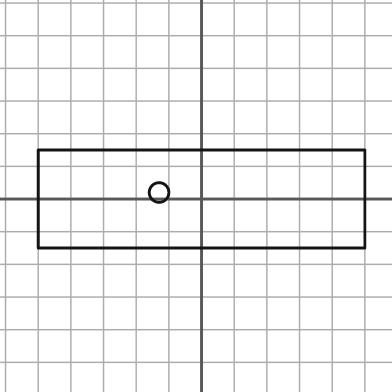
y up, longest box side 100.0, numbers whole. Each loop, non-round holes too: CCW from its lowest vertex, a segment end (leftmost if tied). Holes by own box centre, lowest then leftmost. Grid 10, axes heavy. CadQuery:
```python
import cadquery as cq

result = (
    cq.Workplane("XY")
    .moveTo(-50.0, -15.0)
    .lineTo(50.0, -15.0)
    .lineTo(50.0, 15.0)
    .lineTo(-50.0, 15.0)
    .close()
    .moveTo(-13.0, 2.0)
    .circle(3.0)
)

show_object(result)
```